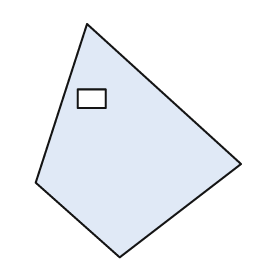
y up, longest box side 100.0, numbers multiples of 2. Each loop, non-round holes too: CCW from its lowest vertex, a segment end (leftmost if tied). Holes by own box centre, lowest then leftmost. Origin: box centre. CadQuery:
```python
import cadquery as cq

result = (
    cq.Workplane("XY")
    .moveTo(-8.0, -50.0)
    .lineTo(44.0, -10.0)
    .lineTo(-22.0, 50.0)
    .lineTo(-44.0, -18.0)
    .close()
    .moveTo(-26.0, 14.0)
    .lineTo(-14.0, 14.0)
    .lineTo(-14.0, 22.0)
    .lineTo(-26.0, 22.0)
    .close()
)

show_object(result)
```